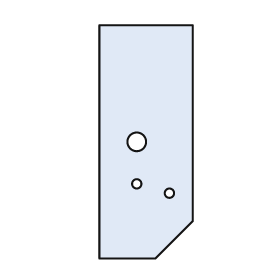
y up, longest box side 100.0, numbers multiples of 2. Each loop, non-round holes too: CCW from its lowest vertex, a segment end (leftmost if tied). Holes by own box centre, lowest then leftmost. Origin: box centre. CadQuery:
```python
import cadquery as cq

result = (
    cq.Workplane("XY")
    .moveTo(-20.0, -50.0)
    .lineTo(4.0, -50.0)
    .lineTo(20.0, -34.0)
    .lineTo(20.0, 50.0)
    .lineTo(-20.0, 50.0)
    .close()
    .moveTo(10.0, -22.0)
    .circle(2.0)
    .moveTo(-4.0, -18.0)
    .circle(2.0)
    .moveTo(-4.0, 0.0)
    .circle(4.0)
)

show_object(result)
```